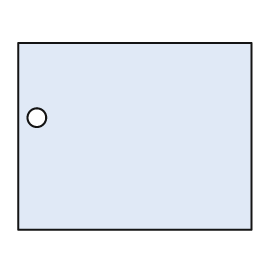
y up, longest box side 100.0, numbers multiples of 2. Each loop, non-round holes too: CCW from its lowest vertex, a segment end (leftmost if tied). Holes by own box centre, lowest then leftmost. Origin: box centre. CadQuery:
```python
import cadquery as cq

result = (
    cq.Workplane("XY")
    .moveTo(-50.0, -40.0)
    .lineTo(50.0, -40.0)
    .lineTo(50.0, 40.0)
    .lineTo(-50.0, 40.0)
    .close()
    .moveTo(-42.0, 8.0)
    .circle(4.0)
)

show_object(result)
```